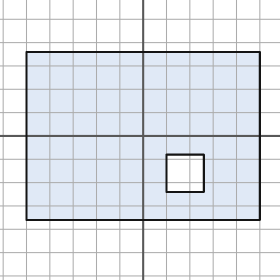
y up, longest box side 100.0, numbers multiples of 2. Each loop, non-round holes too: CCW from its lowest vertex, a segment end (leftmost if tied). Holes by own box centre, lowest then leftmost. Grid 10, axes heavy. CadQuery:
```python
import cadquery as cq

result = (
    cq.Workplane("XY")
    .moveTo(-50.0, -36.0)
    .lineTo(50.0, -36.0)
    .lineTo(50.0, 36.0)
    .lineTo(-50.0, 36.0)
    .close()
    .moveTo(10.0, -24.0)
    .lineTo(26.0, -24.0)
    .lineTo(26.0, -8.0)
    .lineTo(10.0, -8.0)
    .close()
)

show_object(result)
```